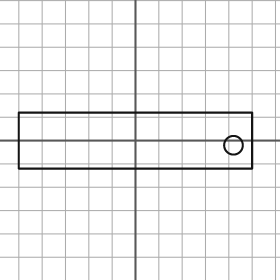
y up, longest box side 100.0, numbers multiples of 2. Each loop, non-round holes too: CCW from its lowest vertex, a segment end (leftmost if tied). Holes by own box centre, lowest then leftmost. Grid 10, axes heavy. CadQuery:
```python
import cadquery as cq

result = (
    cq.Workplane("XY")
    .moveTo(-50.0, -12.0)
    .lineTo(50.0, -12.0)
    .lineTo(50.0, 12.0)
    .lineTo(-50.0, 12.0)
    .close()
    .moveTo(42.0, -2.0)
    .circle(4.0)
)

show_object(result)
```